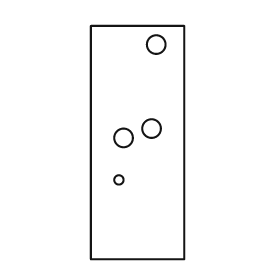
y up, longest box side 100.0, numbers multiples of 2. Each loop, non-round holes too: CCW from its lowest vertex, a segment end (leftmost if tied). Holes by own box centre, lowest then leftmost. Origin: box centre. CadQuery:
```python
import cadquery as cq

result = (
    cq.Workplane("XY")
    .moveTo(-20.0, -50.0)
    .lineTo(20.0, -50.0)
    .lineTo(20.0, 50.0)
    .lineTo(-20.0, 50.0)
    .close()
    .moveTo(-8.0, -16.0)
    .circle(2.0)
    .moveTo(-6.0, 2.0)
    .circle(4.0)
    .moveTo(6.0, 6.0)
    .circle(4.0)
    .moveTo(8.0, 42.0)
    .circle(4.0)
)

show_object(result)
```